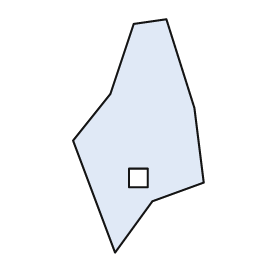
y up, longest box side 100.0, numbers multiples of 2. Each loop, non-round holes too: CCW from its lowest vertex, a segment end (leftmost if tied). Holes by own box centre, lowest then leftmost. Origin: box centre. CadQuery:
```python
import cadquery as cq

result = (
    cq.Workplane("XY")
    .moveTo(-10.0, -50.0)
    .lineTo(6.0, -28.0)
    .lineTo(28.0, -20.0)
    .lineTo(24.0, 12.0)
    .lineTo(12.0, 50.0)
    .lineTo(-2.0, 48.0)
    .lineTo(-12.0, 18.0)
    .lineTo(-28.0, -2.0)
    .close()
    .moveTo(-4.0, -22.0)
    .lineTo(4.0, -22.0)
    .lineTo(4.0, -14.0)
    .lineTo(-4.0, -14.0)
    .close()
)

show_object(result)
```